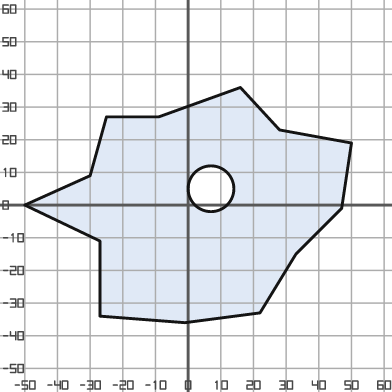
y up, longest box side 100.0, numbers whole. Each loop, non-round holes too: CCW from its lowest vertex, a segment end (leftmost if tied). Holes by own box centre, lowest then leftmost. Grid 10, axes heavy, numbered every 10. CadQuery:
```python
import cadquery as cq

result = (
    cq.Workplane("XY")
    .moveTo(-1.0, -36.0)
    .lineTo(22.0, -33.0)
    .lineTo(33.0, -15.0)
    .lineTo(47.0, -1.0)
    .lineTo(50.0, 19.0)
    .lineTo(28.0, 23.0)
    .lineTo(16.0, 36.0)
    .lineTo(-9.0, 27.0)
    .lineTo(-25.0, 27.0)
    .lineTo(-30.0, 9.0)
    .lineTo(-50.0, 0.0)
    .lineTo(-27.0, -11.0)
    .lineTo(-27.0, -34.0)
    .close()
    .moveTo(7.0, 5.0)
    .circle(7.0)
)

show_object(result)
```